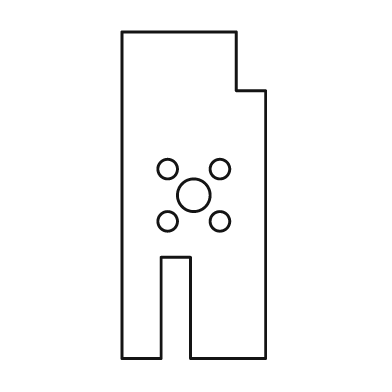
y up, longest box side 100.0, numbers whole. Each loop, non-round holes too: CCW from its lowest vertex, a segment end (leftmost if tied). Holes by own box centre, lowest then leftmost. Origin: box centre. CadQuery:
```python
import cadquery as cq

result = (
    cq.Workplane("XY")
    .moveTo(-22.0, -50.0)
    .lineTo(-10.0, -50.0)
    .lineTo(-10.0, -19.0)
    .lineTo(-1.0, -19.0)
    .lineTo(-1.0, -50.0)
    .lineTo(22.0, -50.0)
    .lineTo(22.0, 32.0)
    .lineTo(13.0, 32.0)
    .lineTo(13.0, 50.0)
    .lineTo(-22.0, 50.0)
    .close()
    .moveTo(-8.0, -8.0)
    .circle(3.0)
    .moveTo(8.0, -8.0)
    .circle(3.0)
    .moveTo(0.0, 0.0)
    .circle(5.0)
    .moveTo(-8.0, 8.0)
    .circle(3.0)
    .moveTo(8.0, 8.0)
    .circle(3.0)
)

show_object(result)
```